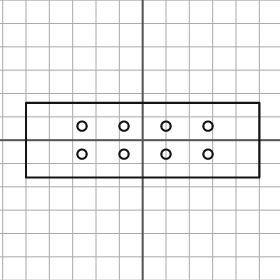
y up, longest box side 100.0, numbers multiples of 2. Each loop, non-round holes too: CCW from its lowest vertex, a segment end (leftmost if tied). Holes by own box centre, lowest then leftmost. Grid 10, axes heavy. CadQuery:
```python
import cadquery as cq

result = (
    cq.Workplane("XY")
    .moveTo(-50.0, -16.0)
    .lineTo(50.0, -16.0)
    .lineTo(50.0, 16.0)
    .lineTo(-50.0, 16.0)
    .close()
    .moveTo(-26.0, -6.0)
    .circle(2.0)
    .moveTo(-8.0, -6.0)
    .circle(2.0)
    .moveTo(10.0, -6.0)
    .circle(2.0)
    .moveTo(28.0, -6.0)
    .circle(2.0)
    .moveTo(-26.0, 6.0)
    .circle(2.0)
    .moveTo(-8.0, 6.0)
    .circle(2.0)
    .moveTo(10.0, 6.0)
    .circle(2.0)
    .moveTo(28.0, 6.0)
    .circle(2.0)
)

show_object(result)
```